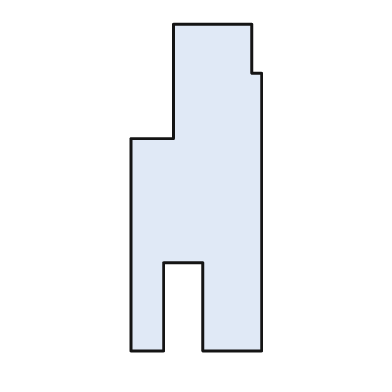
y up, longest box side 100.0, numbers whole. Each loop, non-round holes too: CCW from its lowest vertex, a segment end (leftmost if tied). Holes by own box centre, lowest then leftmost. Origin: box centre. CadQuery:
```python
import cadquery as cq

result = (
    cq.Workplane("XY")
    .moveTo(-20.0, -50.0)
    .lineTo(-10.0, -50.0)
    .lineTo(-10.0, -23.0)
    .lineTo(2.0, -23.0)
    .lineTo(2.0, -50.0)
    .lineTo(20.0, -50.0)
    .lineTo(20.0, 35.0)
    .lineTo(17.0, 35.0)
    .lineTo(17.0, 50.0)
    .lineTo(-7.0, 50.0)
    .lineTo(-7.0, 15.0)
    .lineTo(-20.0, 15.0)
    .close()
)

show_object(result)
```